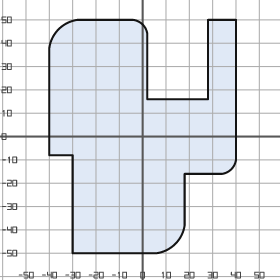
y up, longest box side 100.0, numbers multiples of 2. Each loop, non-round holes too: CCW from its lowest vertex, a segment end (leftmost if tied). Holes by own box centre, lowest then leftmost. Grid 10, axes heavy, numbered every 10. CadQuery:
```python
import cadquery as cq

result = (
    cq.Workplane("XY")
    .moveTo(-30.0, -50.0)
    .lineTo(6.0, -50.0)
    .threePointArc((14.0, -46.0), (18.0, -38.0))
    .lineTo(18.0, -16.0)
    .lineTo(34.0, -16.0)
    .threePointArc((38.0, -14.0), (40.0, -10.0))
    .lineTo(40.0, 50.0)
    .lineTo(28.0, 50.0)
    .lineTo(28.0, 16.0)
    .lineTo(2.0, 16.0)
    .lineTo(2.0, 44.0)
    .threePointArc((0.0, 48.0), (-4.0, 50.0))
    .lineTo(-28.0, 50.0)
    .threePointArc((-36.0, 46.0), (-40.0, 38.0))
    .lineTo(-40.0, -8.0)
    .lineTo(-30.0, -8.0)
    .close()
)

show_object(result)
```